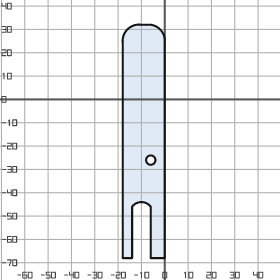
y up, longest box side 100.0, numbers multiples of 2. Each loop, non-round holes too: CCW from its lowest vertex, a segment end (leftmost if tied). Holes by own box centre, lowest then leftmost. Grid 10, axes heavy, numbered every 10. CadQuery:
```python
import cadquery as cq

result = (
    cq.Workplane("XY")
    .moveTo(-18.0, -68.0)
    .lineTo(-14.0, -68.0)
    .lineTo(-14.0, -46.0)
    .threePointArc((-10.0, -44.0), (-6.0, -46.0))
    .lineTo(-6.0, -68.0)
    .lineTo(0.0, -68.0)
    .lineTo(0.0, 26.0)
    .threePointArc((-2.0, 30.0), (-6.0, 32.0))
    .lineTo(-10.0, 32.0)
    .threePointArc((-16.0, 30.0), (-18.0, 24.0))
    .close()
    .moveTo(-6.0, -26.0)
    .circle(2.0)
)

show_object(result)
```